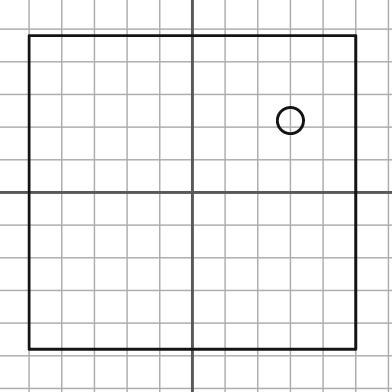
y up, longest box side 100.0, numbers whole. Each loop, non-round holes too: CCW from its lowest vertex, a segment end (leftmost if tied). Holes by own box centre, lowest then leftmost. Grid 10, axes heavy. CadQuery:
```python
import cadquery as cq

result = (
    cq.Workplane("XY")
    .moveTo(-50.0, -48.0)
    .lineTo(50.0, -48.0)
    .lineTo(50.0, 48.0)
    .lineTo(-50.0, 48.0)
    .close()
    .moveTo(30.0, 22.0)
    .circle(4.0)
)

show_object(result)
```